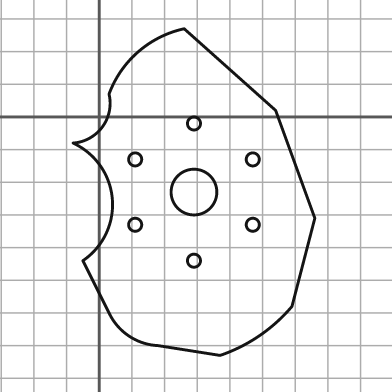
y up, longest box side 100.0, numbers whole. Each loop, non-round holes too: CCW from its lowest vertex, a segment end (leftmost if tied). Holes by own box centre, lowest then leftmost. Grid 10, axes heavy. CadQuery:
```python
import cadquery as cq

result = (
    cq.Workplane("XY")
    .moveTo(37.0, -73.0)
    .threePointArc((49.0, -67.0), (59.0, -58.0))
    .lineTo(66.0, -31.0)
    .lineTo(54.0, 2.0)
    .lineTo(26.0, 27.0)
    .threePointArc((12.0, 20.0), (3.0, 7.0))
    .threePointArc((1.0, -3.0), (-8.0, -8.0))
    .threePointArc((4.0, -25.0), (-5.0, -44.0))
    .lineTo(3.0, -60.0)
    .threePointArc((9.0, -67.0), (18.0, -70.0))
    .close()
    .moveTo(29.0, -44.0)
    .circle(2.0)
    .moveTo(11.0, -33.0)
    .circle(2.0)
    .moveTo(47.0, -33.0)
    .circle(2.0)
    .moveTo(29.0, -23.0)
    .circle(7.0)
    .moveTo(11.0, -13.0)
    .circle(2.0)
    .moveTo(47.0, -13.0)
    .circle(2.0)
    .moveTo(29.0, -2.0)
    .circle(2.0)
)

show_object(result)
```